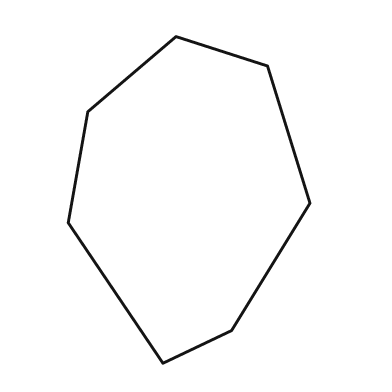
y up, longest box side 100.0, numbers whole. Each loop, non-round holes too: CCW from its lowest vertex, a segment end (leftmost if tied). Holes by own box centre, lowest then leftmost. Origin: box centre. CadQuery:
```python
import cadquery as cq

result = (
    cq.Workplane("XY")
    .moveTo(-8.0, -50.0)
    .lineTo(13.0, -40.0)
    .lineTo(37.0, -1.0)
    .lineTo(24.0, 41.0)
    .lineTo(-4.0, 50.0)
    .lineTo(-31.0, 27.0)
    .lineTo(-37.0, -7.0)
    .close()
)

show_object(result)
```